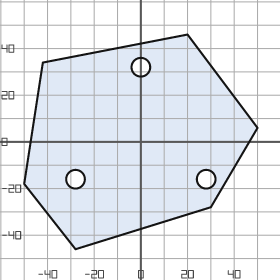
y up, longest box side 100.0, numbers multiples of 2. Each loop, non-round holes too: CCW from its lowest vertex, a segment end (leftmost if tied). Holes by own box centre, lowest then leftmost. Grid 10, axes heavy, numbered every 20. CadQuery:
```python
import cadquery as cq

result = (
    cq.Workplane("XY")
    .moveTo(-28.0, -46.0)
    .lineTo(30.0, -28.0)
    .lineTo(50.0, 6.0)
    .lineTo(20.0, 46.0)
    .lineTo(-42.0, 34.0)
    .lineTo(-50.0, -18.0)
    .close()
    .moveTo(-28.0, -16.0)
    .circle(4.0)
    .moveTo(28.0, -16.0)
    .circle(4.0)
    .moveTo(0.0, 32.0)
    .circle(4.0)
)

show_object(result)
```